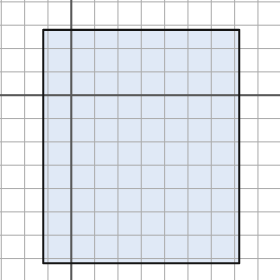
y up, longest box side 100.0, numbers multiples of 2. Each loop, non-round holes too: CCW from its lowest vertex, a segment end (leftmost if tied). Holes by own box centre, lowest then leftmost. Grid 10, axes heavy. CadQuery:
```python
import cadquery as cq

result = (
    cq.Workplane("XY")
    .moveTo(-12.0, -72.0)
    .lineTo(72.0, -72.0)
    .lineTo(72.0, 28.0)
    .lineTo(-12.0, 28.0)
    .close()
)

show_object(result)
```